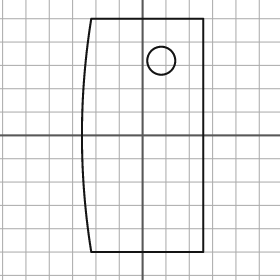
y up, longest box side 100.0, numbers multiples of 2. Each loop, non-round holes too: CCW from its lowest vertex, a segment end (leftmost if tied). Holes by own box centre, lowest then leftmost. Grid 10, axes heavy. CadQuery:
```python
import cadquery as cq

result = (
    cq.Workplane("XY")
    .moveTo(-22.0, -50.0)
    .lineTo(26.0, -50.0)
    .lineTo(26.0, 50.0)
    .lineTo(-22.0, 50.0)
    .threePointArc((-26.0, 0.0), (-22.0, -50.0))
    .close()
    .moveTo(8.0, 32.0)
    .circle(6.0)
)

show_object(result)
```